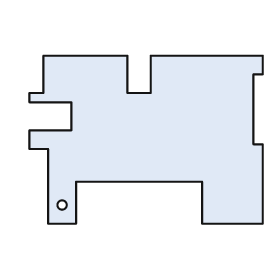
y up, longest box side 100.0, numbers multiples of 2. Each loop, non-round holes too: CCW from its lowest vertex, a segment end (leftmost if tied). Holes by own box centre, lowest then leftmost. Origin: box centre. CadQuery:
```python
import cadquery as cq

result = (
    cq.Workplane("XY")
    .moveTo(-42.0, -36.0)
    .lineTo(-30.0, -36.0)
    .lineTo(-30.0, -18.0)
    .lineTo(24.0, -18.0)
    .lineTo(24.0, -36.0)
    .lineTo(50.0, -36.0)
    .lineTo(50.0, -2.0)
    .lineTo(46.0, -2.0)
    .lineTo(46.0, 28.0)
    .lineTo(50.0, 28.0)
    .lineTo(50.0, 36.0)
    .lineTo(2.0, 36.0)
    .lineTo(2.0, 20.0)
    .lineTo(-8.0, 20.0)
    .lineTo(-8.0, 36.0)
    .lineTo(-44.0, 36.0)
    .lineTo(-44.0, 20.0)
    .lineTo(-50.0, 20.0)
    .lineTo(-50.0, 16.0)
    .lineTo(-32.0, 16.0)
    .lineTo(-32.0, 4.0)
    .lineTo(-50.0, 4.0)
    .lineTo(-50.0, -4.0)
    .lineTo(-42.0, -4.0)
    .close()
    .moveTo(-36.0, -28.0)
    .circle(2.0)
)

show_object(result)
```